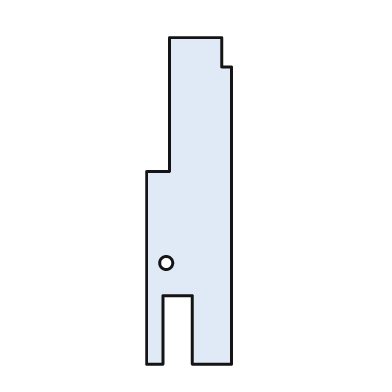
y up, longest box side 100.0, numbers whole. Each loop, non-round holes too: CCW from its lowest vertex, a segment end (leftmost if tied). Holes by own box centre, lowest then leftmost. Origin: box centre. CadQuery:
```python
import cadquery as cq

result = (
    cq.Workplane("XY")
    .moveTo(-13.0, -50.0)
    .lineTo(-8.0, -50.0)
    .lineTo(-8.0, -29.0)
    .lineTo(1.0, -29.0)
    .lineTo(1.0, -50.0)
    .lineTo(13.0, -50.0)
    .lineTo(13.0, 41.0)
    .lineTo(10.0, 41.0)
    .lineTo(10.0, 50.0)
    .lineTo(-6.0, 50.0)
    .lineTo(-6.0, 9.0)
    .lineTo(-13.0, 9.0)
    .close()
    .moveTo(-7.0, -19.0)
    .circle(2.0)
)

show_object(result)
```